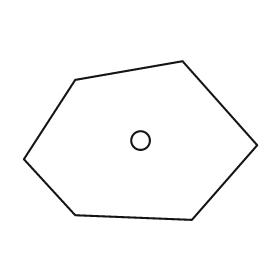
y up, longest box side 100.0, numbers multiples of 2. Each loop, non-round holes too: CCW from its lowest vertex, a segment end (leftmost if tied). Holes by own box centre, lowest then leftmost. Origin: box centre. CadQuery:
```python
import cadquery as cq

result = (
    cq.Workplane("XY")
    .moveTo(22.0, -34.0)
    .lineTo(50.0, -2.0)
    .lineTo(18.0, 34.0)
    .lineTo(-28.0, 26.0)
    .lineTo(-50.0, -8.0)
    .lineTo(-28.0, -32.0)
    .close()
    .moveTo(0.0, 0.0)
    .circle(4.0)
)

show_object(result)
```